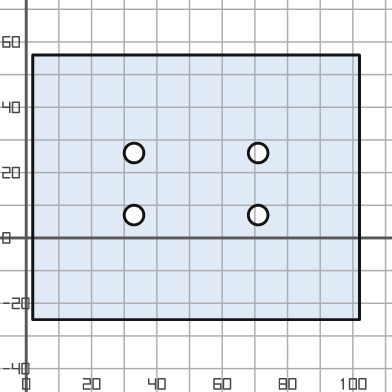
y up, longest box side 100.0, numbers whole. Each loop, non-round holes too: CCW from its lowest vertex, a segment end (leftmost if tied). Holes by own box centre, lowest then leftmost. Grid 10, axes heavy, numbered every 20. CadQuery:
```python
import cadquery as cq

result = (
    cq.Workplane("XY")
    .moveTo(2.0, -25.0)
    .lineTo(102.0, -25.0)
    .lineTo(102.0, 56.0)
    .lineTo(2.0, 56.0)
    .close()
    .moveTo(33.0, 7.0)
    .circle(3.0)
    .moveTo(71.0, 7.0)
    .circle(3.0)
    .moveTo(33.0, 26.0)
    .circle(3.0)
    .moveTo(71.0, 26.0)
    .circle(3.0)
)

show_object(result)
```